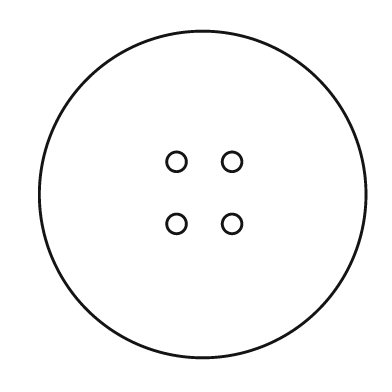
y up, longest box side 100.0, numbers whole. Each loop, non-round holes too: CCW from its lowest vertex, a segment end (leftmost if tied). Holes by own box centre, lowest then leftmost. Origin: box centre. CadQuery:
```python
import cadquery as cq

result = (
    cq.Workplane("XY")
    .moveTo(0.0, 0.0)
    .circle(50.0)
    .moveTo(-8.0, -9.0)
    .circle(3.0)
    .moveTo(9.0, -9.0)
    .circle(3.0)
    .moveTo(-8.0, 10.0)
    .circle(3.0)
    .moveTo(9.0, 10.0)
    .circle(3.0)
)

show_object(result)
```